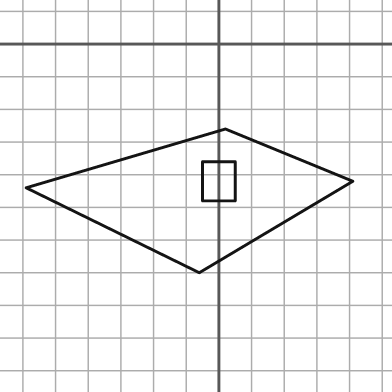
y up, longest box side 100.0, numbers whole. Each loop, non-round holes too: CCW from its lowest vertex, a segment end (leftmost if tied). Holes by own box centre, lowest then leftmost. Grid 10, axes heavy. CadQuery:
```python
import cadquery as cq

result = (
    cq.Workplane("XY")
    .moveTo(-6.0, -70.0)
    .lineTo(41.0, -42.0)
    .lineTo(2.0, -26.0)
    .lineTo(-59.0, -44.0)
    .close()
    .moveTo(-5.0, -48.0)
    .lineTo(5.0, -48.0)
    .lineTo(5.0, -36.0)
    .lineTo(-5.0, -36.0)
    .close()
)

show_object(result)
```